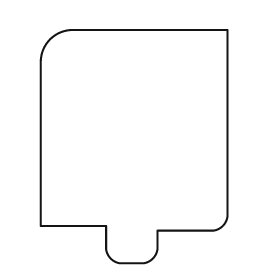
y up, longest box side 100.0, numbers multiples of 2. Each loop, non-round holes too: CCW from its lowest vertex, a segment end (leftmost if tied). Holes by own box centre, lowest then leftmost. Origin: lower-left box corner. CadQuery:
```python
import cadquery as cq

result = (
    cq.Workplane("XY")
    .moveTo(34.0, 0.0)
    .lineTo(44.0, 0.0)
    .threePointArc((48.0, 2.0), (50.0, 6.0))
    .lineTo(50.0, 14.0)
    .lineTo(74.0, 14.0)
    .threePointArc((78.0, 16.0), (80.0, 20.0))
    .lineTo(80.0, 100.0)
    .lineTo(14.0, 100.0)
    .threePointArc((4.0, 96.0), (0.0, 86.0))
    .lineTo(0.0, 16.0)
    .lineTo(28.0, 16.0)
    .lineTo(28.0, 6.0)
    .threePointArc((30.0, 2.0), (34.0, 0.0))
    .close()
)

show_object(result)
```